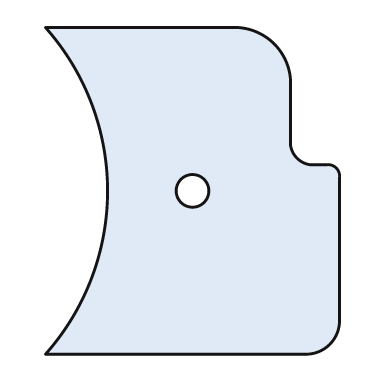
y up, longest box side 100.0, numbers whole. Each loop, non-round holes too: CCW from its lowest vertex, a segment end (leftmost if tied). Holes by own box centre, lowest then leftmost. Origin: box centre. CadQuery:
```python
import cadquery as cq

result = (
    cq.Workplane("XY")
    .moveTo(-45.0, -50.0)
    .lineTo(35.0, -50.0)
    .threePointArc((42.0, -47.0), (45.0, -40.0))
    .lineTo(45.0, 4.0)
    .threePointArc((44.0, 7.0), (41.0, 8.0))
    .lineTo(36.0, 8.0)
    .threePointArc((32.0, 10.0), (30.0, 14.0))
    .lineTo(30.0, 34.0)
    .threePointArc((25.0, 45.0), (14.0, 50.0))
    .lineTo(-45.0, 50.0)
    .threePointArc((-26.0, 0.0), (-45.0, -50.0))
    .close()
    .moveTo(0.0, 0.0)
    .circle(5.0)
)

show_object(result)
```